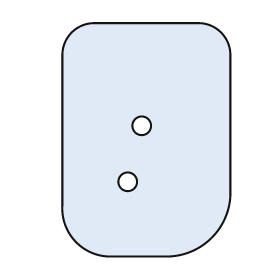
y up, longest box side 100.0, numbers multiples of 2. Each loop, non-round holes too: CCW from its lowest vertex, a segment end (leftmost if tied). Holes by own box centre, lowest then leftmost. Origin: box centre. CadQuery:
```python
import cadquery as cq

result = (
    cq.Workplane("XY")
    .moveTo(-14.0, -50.0)
    .lineTo(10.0, -50.0)
    .threePointArc((28.0, -42.0), (36.0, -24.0))
    .lineTo(36.0, 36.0)
    .threePointArc((32.0, 46.0), (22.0, 50.0))
    .lineTo(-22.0, 50.0)
    .threePointArc((-32.0, 46.0), (-36.0, 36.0))
    .lineTo(-36.0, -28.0)
    .threePointArc((-30.0, -44.0), (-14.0, -50.0))
    .close()
    .moveTo(-8.0, -18.0)
    .circle(4.0)
    .moveTo(-2.0, 6.0)
    .circle(4.0)
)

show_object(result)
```